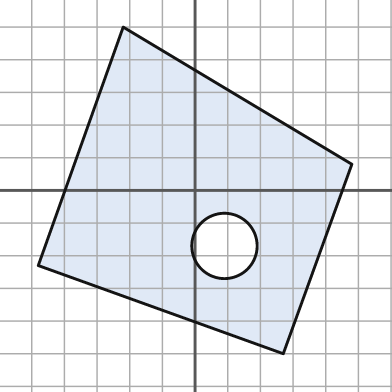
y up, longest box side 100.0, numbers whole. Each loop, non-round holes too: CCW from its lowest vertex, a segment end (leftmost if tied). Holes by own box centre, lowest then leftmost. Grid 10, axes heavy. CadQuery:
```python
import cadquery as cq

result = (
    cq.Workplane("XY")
    .moveTo(27.0, -50.0)
    .lineTo(48.0, 8.0)
    .lineTo(-22.0, 50.0)
    .lineTo(-48.0, -23.0)
    .close()
    .moveTo(9.0, -17.0)
    .circle(10.0)
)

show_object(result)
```